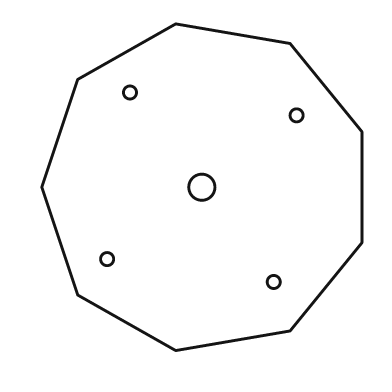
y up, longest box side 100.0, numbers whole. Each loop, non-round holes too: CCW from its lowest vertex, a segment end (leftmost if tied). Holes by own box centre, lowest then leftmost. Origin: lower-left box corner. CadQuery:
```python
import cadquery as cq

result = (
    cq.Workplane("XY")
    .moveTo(41.0, 0.0)
    .lineTo(76.0, 6.0)
    .lineTo(98.0, 33.0)
    .lineTo(98.0, 67.0)
    .lineTo(76.0, 94.0)
    .lineTo(41.0, 100.0)
    .lineTo(11.0, 83.0)
    .lineTo(0.0, 50.0)
    .lineTo(11.0, 17.0)
    .close()
    .moveTo(71.0, 21.0)
    .circle(2.0)
    .moveTo(20.0, 28.0)
    .circle(2.0)
    .moveTo(49.0, 50.0)
    .circle(4.0)
    .moveTo(78.0, 72.0)
    .circle(2.0)
    .moveTo(27.0, 79.0)
    .circle(2.0)
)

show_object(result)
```